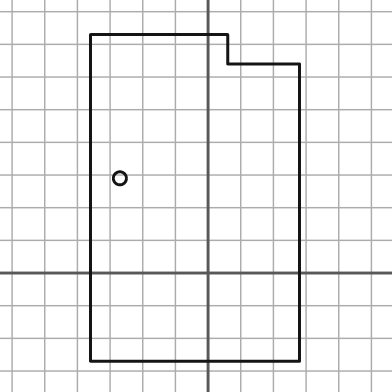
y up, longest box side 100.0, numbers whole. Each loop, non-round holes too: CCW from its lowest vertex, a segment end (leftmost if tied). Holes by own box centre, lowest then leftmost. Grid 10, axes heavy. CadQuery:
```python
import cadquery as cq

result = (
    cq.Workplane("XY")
    .moveTo(-36.0, -27.0)
    .lineTo(28.0, -27.0)
    .lineTo(28.0, 64.0)
    .lineTo(6.0, 64.0)
    .lineTo(6.0, 73.0)
    .lineTo(-36.0, 73.0)
    .close()
    .moveTo(-27.0, 29.0)
    .circle(2.0)
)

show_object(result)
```